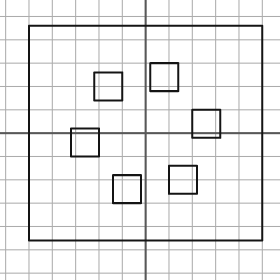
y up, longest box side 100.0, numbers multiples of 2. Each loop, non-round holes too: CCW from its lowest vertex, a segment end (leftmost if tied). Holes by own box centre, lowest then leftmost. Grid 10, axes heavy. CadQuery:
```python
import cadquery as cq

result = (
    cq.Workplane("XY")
    .moveTo(-50.0, -46.0)
    .lineTo(50.0, -46.0)
    .lineTo(50.0, 46.0)
    .lineTo(-50.0, 46.0)
    .close()
    .moveTo(-14.0, -30.0)
    .lineTo(-2.0, -30.0)
    .lineTo(-2.0, -18.0)
    .lineTo(-14.0, -18.0)
    .close()
    .moveTo(10.0, -26.0)
    .lineTo(22.0, -26.0)
    .lineTo(22.0, -14.0)
    .lineTo(10.0, -14.0)
    .close()
    .moveTo(-32.0, -10.0)
    .lineTo(-20.0, -10.0)
    .lineTo(-20.0, 2.0)
    .lineTo(-32.0, 2.0)
    .close()
    .moveTo(20.0, -2.0)
    .lineTo(32.0, -2.0)
    .lineTo(32.0, 10.0)
    .lineTo(20.0, 10.0)
    .close()
    .moveTo(-22.0, 14.0)
    .lineTo(-10.0, 14.0)
    .lineTo(-10.0, 26.0)
    .lineTo(-22.0, 26.0)
    .close()
    .moveTo(2.0, 18.0)
    .lineTo(14.0, 18.0)
    .lineTo(14.0, 30.0)
    .lineTo(2.0, 30.0)
    .close()
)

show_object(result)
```